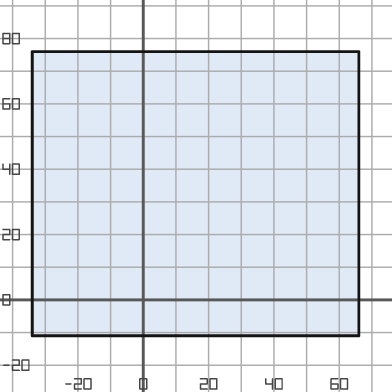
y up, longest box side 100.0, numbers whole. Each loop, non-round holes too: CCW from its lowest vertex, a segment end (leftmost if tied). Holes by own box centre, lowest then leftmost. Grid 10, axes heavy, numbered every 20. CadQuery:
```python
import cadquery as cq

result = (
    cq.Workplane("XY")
    .moveTo(-34.0, -11.0)
    .lineTo(66.0, -11.0)
    .lineTo(66.0, 76.0)
    .lineTo(-34.0, 76.0)
    .close()
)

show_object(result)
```